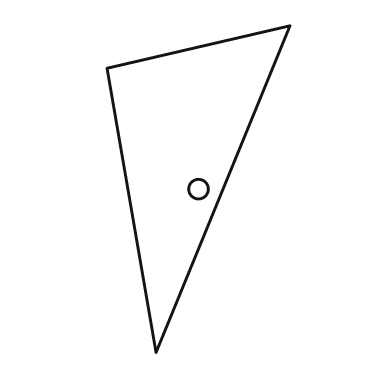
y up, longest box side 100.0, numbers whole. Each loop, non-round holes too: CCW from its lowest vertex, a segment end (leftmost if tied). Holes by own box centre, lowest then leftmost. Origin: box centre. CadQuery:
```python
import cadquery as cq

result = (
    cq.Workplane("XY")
    .moveTo(-13.0, -50.0)
    .lineTo(28.0, 50.0)
    .lineTo(-28.0, 37.0)
    .close()
    .moveTo(0.0, 0.0)
    .circle(3.0)
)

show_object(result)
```